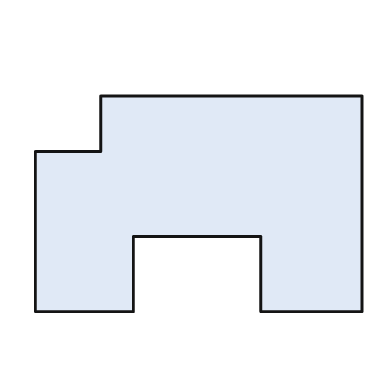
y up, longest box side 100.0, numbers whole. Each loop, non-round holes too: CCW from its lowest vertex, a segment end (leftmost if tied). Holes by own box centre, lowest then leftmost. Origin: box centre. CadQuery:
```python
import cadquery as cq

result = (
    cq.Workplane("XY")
    .moveTo(-50.0, -33.0)
    .lineTo(-20.0, -33.0)
    .lineTo(-20.0, -10.0)
    .lineTo(19.0, -10.0)
    .lineTo(19.0, -33.0)
    .lineTo(50.0, -33.0)
    .lineTo(50.0, 33.0)
    .lineTo(-30.0, 33.0)
    .lineTo(-30.0, 16.0)
    .lineTo(-50.0, 16.0)
    .close()
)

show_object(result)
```